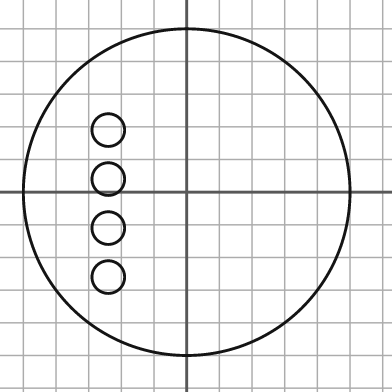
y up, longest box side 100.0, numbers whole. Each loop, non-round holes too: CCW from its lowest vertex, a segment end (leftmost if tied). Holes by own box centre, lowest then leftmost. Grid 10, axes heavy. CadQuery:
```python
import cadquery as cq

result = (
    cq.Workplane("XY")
    .moveTo(0.0, 0.0)
    .circle(50.0)
    .moveTo(-24.0, -26.0)
    .circle(5.0)
    .moveTo(-24.0, -11.0)
    .circle(5.0)
    .moveTo(-24.0, 4.0)
    .circle(5.0)
    .moveTo(-24.0, 19.0)
    .circle(5.0)
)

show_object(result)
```